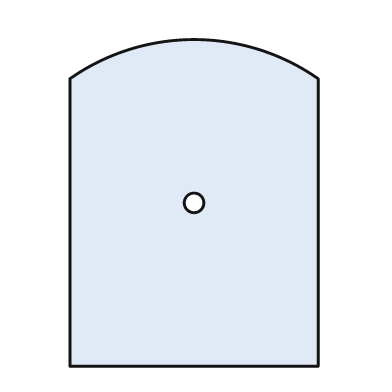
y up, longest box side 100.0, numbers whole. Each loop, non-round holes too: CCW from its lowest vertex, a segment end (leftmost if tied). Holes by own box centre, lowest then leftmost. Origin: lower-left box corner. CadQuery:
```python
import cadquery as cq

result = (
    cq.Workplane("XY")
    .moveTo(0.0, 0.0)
    .lineTo(76.0, 0.0)
    .lineTo(76.0, 88.0)
    .threePointArc((38.0, 100.0), (0.0, 88.0))
    .close()
    .moveTo(38.0, 50.0)
    .circle(3.0)
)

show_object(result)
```